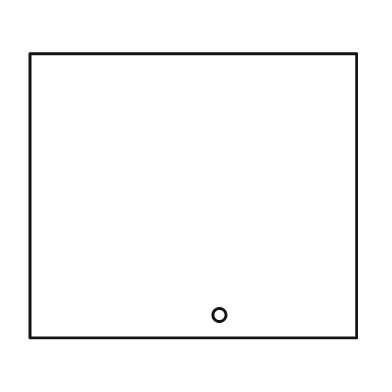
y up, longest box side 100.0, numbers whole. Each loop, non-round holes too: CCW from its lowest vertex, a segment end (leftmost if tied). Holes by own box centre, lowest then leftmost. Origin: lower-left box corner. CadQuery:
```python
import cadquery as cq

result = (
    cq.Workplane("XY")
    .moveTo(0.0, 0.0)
    .lineTo(100.0, 0.0)
    .lineTo(100.0, 87.0)
    .lineTo(0.0, 87.0)
    .close()
    .moveTo(58.0, 7.0)
    .circle(2.0)
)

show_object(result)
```